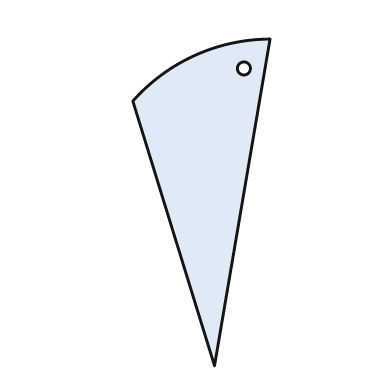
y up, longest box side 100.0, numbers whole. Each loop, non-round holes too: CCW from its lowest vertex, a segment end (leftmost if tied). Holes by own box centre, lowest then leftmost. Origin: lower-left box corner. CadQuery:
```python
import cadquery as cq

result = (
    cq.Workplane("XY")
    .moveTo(25.0, 0.0)
    .lineTo(42.0, 100.0)
    .threePointArc((19.0, 95.0), (0.0, 81.0))
    .close()
    .moveTo(34.0, 91.0)
    .circle(2.0)
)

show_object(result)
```